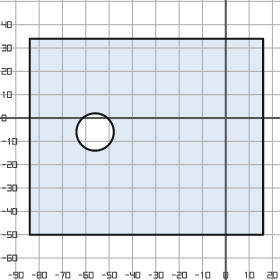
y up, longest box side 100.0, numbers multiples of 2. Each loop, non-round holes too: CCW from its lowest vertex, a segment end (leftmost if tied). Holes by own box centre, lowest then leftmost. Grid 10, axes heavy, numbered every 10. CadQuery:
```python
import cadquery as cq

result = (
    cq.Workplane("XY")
    .moveTo(-84.0, -50.0)
    .lineTo(16.0, -50.0)
    .lineTo(16.0, 34.0)
    .lineTo(-84.0, 34.0)
    .close()
    .moveTo(-56.0, -6.0)
    .circle(8.0)
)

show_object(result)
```